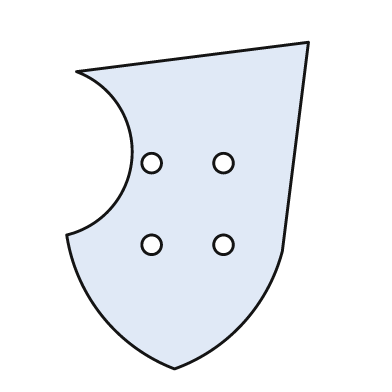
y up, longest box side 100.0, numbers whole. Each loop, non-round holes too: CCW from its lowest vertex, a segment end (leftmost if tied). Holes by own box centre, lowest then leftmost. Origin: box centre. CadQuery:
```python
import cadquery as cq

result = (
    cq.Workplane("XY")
    .moveTo(-4.0, -50.0)
    .threePointArc((17.0, -36.0), (29.0, -14.0))
    .lineTo(37.0, 50.0)
    .lineTo(-34.0, 41.0)
    .threePointArc((-17.0, 15.0), (-37.0, -9.0))
    .threePointArc((-26.0, -34.0), (-4.0, -50.0))
    .close()
    .moveTo(-11.0, -12.0)
    .circle(3.0)
    .moveTo(11.0, -12.0)
    .circle(3.0)
    .moveTo(-11.0, 13.0)
    .circle(3.0)
    .moveTo(11.0, 13.0)
    .circle(3.0)
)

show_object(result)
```